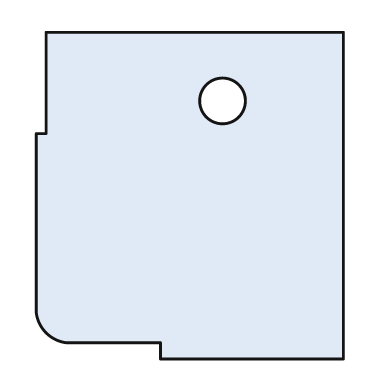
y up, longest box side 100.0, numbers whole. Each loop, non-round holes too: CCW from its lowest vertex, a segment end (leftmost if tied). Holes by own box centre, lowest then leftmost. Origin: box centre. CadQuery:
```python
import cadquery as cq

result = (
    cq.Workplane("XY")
    .moveTo(-9.0, -50.0)
    .lineTo(47.0, -50.0)
    .lineTo(47.0, 50.0)
    .lineTo(-44.0, 50.0)
    .lineTo(-44.0, 19.0)
    .lineTo(-47.0, 19.0)
    .lineTo(-47.0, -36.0)
    .threePointArc((-44.0, -42.0), (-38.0, -45.0))
    .lineTo(-9.0, -45.0)
    .close()
    .moveTo(10.0, 29.0)
    .circle(7.0)
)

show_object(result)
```